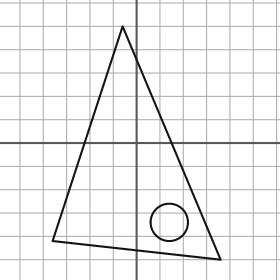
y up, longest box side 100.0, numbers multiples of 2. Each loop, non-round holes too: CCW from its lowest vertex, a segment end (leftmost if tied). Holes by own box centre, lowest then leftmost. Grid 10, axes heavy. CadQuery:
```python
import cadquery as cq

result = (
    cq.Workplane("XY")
    .moveTo(36.0, -50.0)
    .lineTo(-6.0, 50.0)
    .lineTo(-36.0, -42.0)
    .close()
    .moveTo(14.0, -34.0)
    .circle(8.0)
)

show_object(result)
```